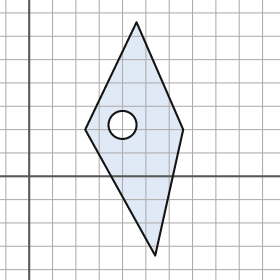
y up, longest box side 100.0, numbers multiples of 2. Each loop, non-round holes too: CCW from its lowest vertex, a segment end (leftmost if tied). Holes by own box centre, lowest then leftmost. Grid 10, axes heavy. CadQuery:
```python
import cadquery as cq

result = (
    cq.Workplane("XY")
    .moveTo(54.0, -34.0)
    .lineTo(66.0, 20.0)
    .lineTo(46.0, 66.0)
    .lineTo(24.0, 20.0)
    .close()
    .moveTo(40.0, 22.0)
    .circle(6.0)
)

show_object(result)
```